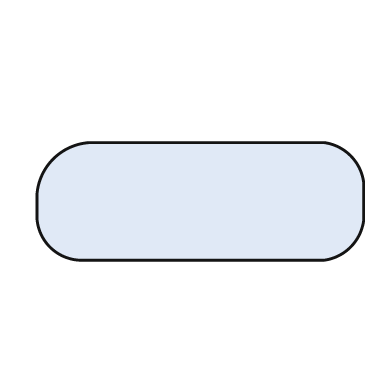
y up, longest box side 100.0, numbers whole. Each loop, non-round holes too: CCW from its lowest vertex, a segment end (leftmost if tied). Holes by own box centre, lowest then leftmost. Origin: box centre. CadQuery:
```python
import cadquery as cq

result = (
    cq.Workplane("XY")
    .moveTo(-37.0, -18.0)
    .lineTo(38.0, -18.0)
    .threePointArc((46.0, -14.0), (50.0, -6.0))
    .lineTo(50.0, 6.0)
    .threePointArc((46.0, 14.0), (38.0, 18.0))
    .lineTo(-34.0, 18.0)
    .threePointArc((-45.0, 13.0), (-50.0, 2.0))
    .lineTo(-50.0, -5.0)
    .threePointArc((-46.0, -14.0), (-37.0, -18.0))
    .close()
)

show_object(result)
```